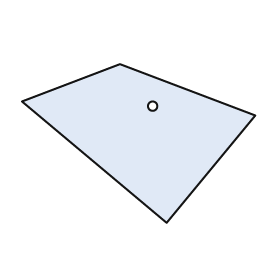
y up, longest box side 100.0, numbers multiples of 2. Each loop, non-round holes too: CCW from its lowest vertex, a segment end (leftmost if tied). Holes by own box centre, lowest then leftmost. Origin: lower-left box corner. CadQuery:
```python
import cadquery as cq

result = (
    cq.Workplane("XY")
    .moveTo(62.0, 0.0)
    .lineTo(100.0, 46.0)
    .lineTo(42.0, 68.0)
    .lineTo(0.0, 52.0)
    .close()
    .moveTo(56.0, 50.0)
    .circle(2.0)
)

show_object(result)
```